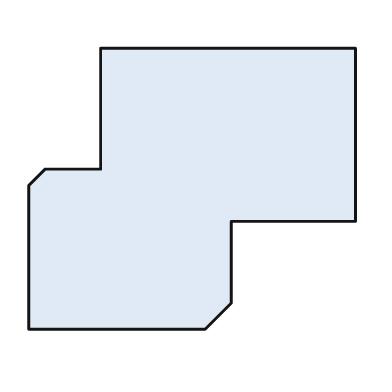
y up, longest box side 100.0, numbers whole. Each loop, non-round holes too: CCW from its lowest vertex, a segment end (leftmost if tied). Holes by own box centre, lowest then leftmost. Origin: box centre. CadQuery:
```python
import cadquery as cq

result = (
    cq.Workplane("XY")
    .moveTo(-50.0, -43.0)
    .lineTo(4.0, -43.0)
    .lineTo(12.0, -35.0)
    .lineTo(12.0, -10.0)
    .lineTo(50.0, -10.0)
    .lineTo(50.0, 43.0)
    .lineTo(-28.0, 43.0)
    .lineTo(-28.0, 6.0)
    .lineTo(-45.0, 6.0)
    .lineTo(-50.0, 1.0)
    .close()
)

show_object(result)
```